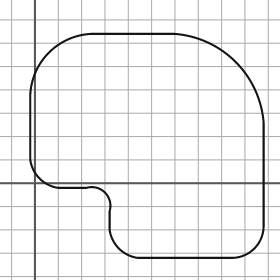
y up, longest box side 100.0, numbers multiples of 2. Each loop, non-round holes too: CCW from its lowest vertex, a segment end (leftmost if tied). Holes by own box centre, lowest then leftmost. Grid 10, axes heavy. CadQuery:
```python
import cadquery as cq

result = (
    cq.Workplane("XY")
    .moveTo(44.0, -32.0)
    .lineTo(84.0, -32.0)
    .threePointArc((94.0, -28.0), (98.0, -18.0))
    .lineTo(98.0, 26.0)
    .threePointArc((86.0, 52.0), (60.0, 64.0))
    .lineTo(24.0, 64.0)
    .threePointArc((6.0, 56.0), (-2.0, 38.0))
    .lineTo(-2.0, 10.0)
    .threePointArc((2.0, 2.0), (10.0, -2.0))
    .lineTo(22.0, -2.0)
    .threePointArc((30.0, -4.0), (32.0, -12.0))
    .lineTo(32.0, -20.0)
    .threePointArc((36.0, -28.0), (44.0, -32.0))
    .close()
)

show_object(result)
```